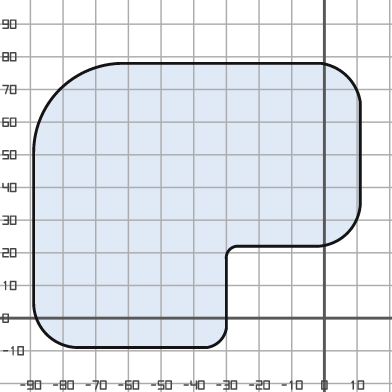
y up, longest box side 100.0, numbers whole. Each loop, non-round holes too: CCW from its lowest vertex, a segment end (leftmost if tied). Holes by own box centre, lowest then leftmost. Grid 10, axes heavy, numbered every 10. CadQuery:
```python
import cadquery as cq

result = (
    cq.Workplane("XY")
    .moveTo(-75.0, -9.0)
    .lineTo(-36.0, -9.0)
    .threePointArc((-32.0, -7.0), (-30.0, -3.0))
    .lineTo(-30.0, 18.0)
    .threePointArc((-29.0, 21.0), (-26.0, 22.0))
    .lineTo(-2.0, 22.0)
    .threePointArc((7.0, 26.0), (11.0, 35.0))
    .lineTo(11.0, 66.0)
    .threePointArc((7.0, 74.0), (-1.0, 78.0))
    .lineTo(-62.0, 78.0)
    .threePointArc((-81.0, 70.0), (-89.0, 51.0))
    .lineTo(-89.0, 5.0)
    .threePointArc((-85.0, -5.0), (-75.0, -9.0))
    .close()
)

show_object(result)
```